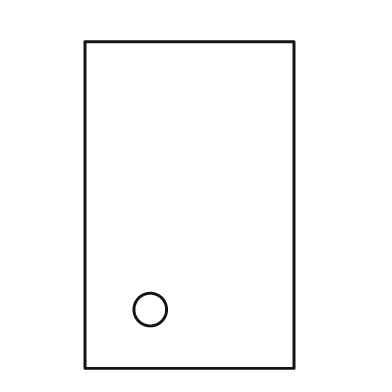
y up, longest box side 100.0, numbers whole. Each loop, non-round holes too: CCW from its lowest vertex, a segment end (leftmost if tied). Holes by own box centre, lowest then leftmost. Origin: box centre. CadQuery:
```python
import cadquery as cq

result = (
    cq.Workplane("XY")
    .moveTo(-32.0, -50.0)
    .lineTo(32.0, -50.0)
    .lineTo(32.0, 50.0)
    .lineTo(-32.0, 50.0)
    .close()
    .moveTo(-12.0, -32.0)
    .circle(5.0)
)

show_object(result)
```